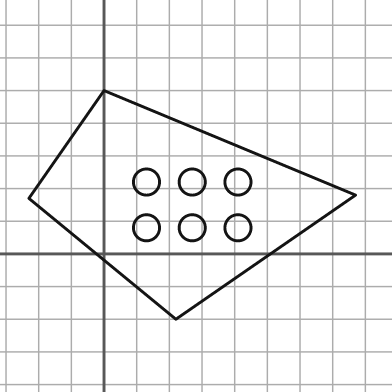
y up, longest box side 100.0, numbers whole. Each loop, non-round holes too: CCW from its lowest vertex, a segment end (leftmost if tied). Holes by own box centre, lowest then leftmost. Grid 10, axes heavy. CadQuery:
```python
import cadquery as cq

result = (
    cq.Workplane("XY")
    .moveTo(22.0, -20.0)
    .lineTo(77.0, 18.0)
    .lineTo(0.0, 50.0)
    .lineTo(-23.0, 17.0)
    .close()
    .moveTo(13.0, 8.0)
    .circle(4.0)
    .moveTo(27.0, 8.0)
    .circle(4.0)
    .moveTo(41.0, 8.0)
    .circle(4.0)
    .moveTo(13.0, 22.0)
    .circle(4.0)
    .moveTo(27.0, 22.0)
    .circle(4.0)
    .moveTo(41.0, 22.0)
    .circle(4.0)
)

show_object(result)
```